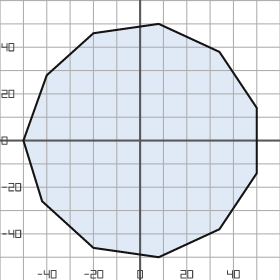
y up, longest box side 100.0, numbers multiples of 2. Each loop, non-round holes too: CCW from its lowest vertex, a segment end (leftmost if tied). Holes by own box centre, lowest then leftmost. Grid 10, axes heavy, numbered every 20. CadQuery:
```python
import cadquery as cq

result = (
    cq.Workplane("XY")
    .moveTo(8.0, -50.0)
    .lineTo(34.0, -38.0)
    .lineTo(50.0, -14.0)
    .lineTo(50.0, 14.0)
    .lineTo(34.0, 38.0)
    .lineTo(8.0, 50.0)
    .lineTo(-20.0, 46.0)
    .lineTo(-40.0, 28.0)
    .lineTo(-50.0, 0.0)
    .lineTo(-42.0, -26.0)
    .lineTo(-20.0, -46.0)
    .close()
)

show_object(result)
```